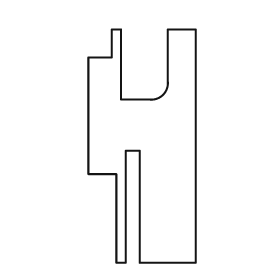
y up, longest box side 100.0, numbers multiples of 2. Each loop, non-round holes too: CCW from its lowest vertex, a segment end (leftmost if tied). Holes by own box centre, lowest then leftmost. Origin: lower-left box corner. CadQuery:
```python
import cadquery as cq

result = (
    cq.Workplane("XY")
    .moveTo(12.0, 0.0)
    .lineTo(16.0, 0.0)
    .lineTo(16.0, 48.0)
    .lineTo(22.0, 48.0)
    .lineTo(22.0, 0.0)
    .lineTo(46.0, 0.0)
    .lineTo(46.0, 100.0)
    .lineTo(34.0, 100.0)
    .lineTo(34.0, 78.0)
    .threePointArc((32.0, 72.0), (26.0, 70.0))
    .lineTo(14.0, 70.0)
    .lineTo(14.0, 100.0)
    .lineTo(10.0, 100.0)
    .lineTo(10.0, 88.0)
    .lineTo(0.0, 88.0)
    .lineTo(0.0, 38.0)
    .lineTo(12.0, 38.0)
    .close()
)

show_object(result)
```